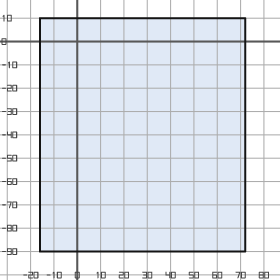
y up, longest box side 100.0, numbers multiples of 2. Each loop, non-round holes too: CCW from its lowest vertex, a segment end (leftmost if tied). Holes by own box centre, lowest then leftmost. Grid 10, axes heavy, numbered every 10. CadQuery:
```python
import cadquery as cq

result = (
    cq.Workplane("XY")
    .moveTo(-16.0, -90.0)
    .lineTo(72.0, -90.0)
    .lineTo(72.0, 10.0)
    .lineTo(-16.0, 10.0)
    .close()
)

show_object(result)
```